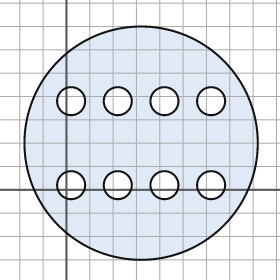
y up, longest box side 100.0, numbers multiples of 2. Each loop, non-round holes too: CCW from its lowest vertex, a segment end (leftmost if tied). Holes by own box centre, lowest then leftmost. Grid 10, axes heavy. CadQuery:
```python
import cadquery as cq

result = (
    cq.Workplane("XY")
    .moveTo(32.0, 20.0)
    .circle(50.0)
    .moveTo(2.0, 2.0)
    .circle(6.0)
    .moveTo(22.0, 2.0)
    .circle(6.0)
    .moveTo(42.0, 2.0)
    .circle(6.0)
    .moveTo(62.0, 2.0)
    .circle(6.0)
    .moveTo(2.0, 38.0)
    .circle(6.0)
    .moveTo(22.0, 38.0)
    .circle(6.0)
    .moveTo(42.0, 38.0)
    .circle(6.0)
    .moveTo(62.0, 38.0)
    .circle(6.0)
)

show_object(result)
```